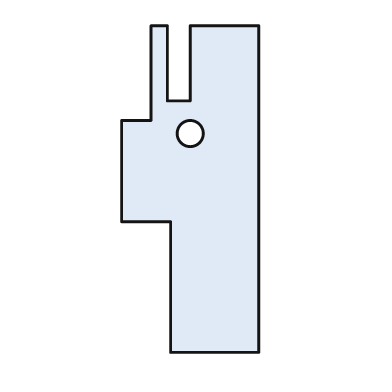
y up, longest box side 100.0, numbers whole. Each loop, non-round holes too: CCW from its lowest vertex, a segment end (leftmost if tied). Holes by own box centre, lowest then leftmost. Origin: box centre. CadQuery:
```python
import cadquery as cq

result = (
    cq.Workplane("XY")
    .moveTo(-6.0, -50.0)
    .lineTo(21.0, -50.0)
    .lineTo(21.0, 50.0)
    .lineTo(0.0, 50.0)
    .lineTo(0.0, 27.0)
    .lineTo(-7.0, 27.0)
    .lineTo(-7.0, 50.0)
    .lineTo(-12.0, 50.0)
    .lineTo(-12.0, 21.0)
    .lineTo(-21.0, 21.0)
    .lineTo(-21.0, -10.0)
    .lineTo(-6.0, -10.0)
    .close()
    .moveTo(0.0, 17.0)
    .circle(4.0)
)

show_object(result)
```